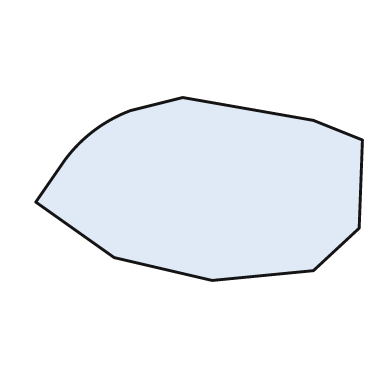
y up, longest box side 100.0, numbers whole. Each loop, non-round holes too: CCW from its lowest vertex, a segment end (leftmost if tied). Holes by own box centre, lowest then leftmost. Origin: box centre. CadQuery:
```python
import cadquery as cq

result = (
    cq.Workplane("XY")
    .moveTo(4.0, -28.0)
    .lineTo(35.0, -25.0)
    .lineTo(49.0, -12.0)
    .lineTo(50.0, 15.0)
    .lineTo(35.0, 21.0)
    .lineTo(-5.0, 28.0)
    .lineTo(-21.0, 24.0)
    .threePointArc((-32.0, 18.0), (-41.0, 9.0))
    .lineTo(-50.0, -4.0)
    .lineTo(-26.0, -21.0)
    .close()
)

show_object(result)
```